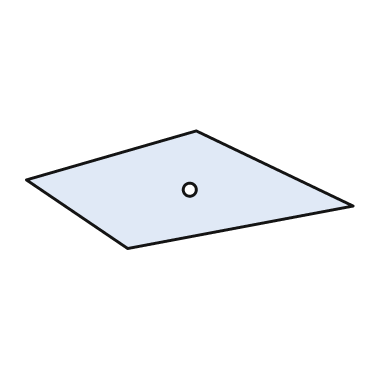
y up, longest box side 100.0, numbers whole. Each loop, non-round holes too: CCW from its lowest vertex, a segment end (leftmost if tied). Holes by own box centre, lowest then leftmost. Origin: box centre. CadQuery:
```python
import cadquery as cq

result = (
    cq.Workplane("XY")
    .moveTo(-19.0, -18.0)
    .lineTo(50.0, -5.0)
    .lineTo(2.0, 18.0)
    .lineTo(-50.0, 3.0)
    .close()
    .moveTo(0.0, 0.0)
    .circle(2.0)
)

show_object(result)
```